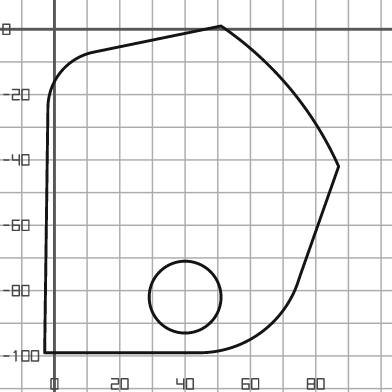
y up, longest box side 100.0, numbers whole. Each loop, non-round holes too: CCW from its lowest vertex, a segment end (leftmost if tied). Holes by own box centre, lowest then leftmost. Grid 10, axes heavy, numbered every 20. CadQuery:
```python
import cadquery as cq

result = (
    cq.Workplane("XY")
    .moveTo(-3.0, -99.0)
    .lineTo(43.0, -99.0)
    .threePointArc((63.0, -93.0), (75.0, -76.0))
    .lineTo(87.0, -42.0)
    .threePointArc((72.0, -18.0), (51.0, 1.0))
    .lineTo(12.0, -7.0)
    .threePointArc((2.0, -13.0), (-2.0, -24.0))
    .close()
    .moveTo(40.0, -82.0)
    .circle(11.0)
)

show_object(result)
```